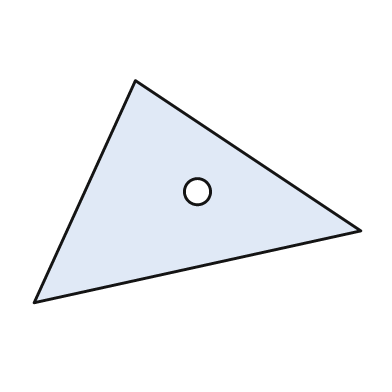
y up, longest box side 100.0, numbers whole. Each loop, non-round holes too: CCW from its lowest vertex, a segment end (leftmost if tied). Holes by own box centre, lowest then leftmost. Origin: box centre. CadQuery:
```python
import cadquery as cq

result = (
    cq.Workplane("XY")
    .moveTo(-50.0, -34.0)
    .lineTo(50.0, -12.0)
    .lineTo(-19.0, 34.0)
    .close()
    .moveTo(0.0, 0.0)
    .circle(4.0)
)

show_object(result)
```